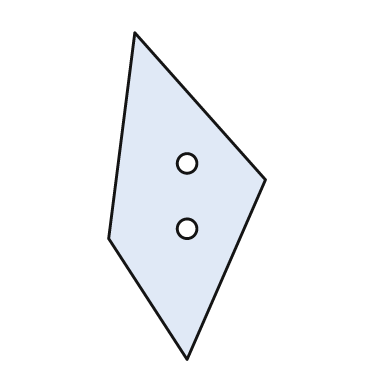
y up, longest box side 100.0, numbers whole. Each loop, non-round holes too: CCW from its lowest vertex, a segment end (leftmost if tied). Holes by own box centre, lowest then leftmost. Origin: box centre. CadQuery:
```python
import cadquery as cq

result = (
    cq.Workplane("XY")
    .moveTo(0.0, -50.0)
    .lineTo(24.0, 5.0)
    .lineTo(-16.0, 50.0)
    .lineTo(-24.0, -13.0)
    .close()
    .moveTo(0.0, -10.0)
    .circle(3.0)
    .moveTo(0.0, 10.0)
    .circle(3.0)
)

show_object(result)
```